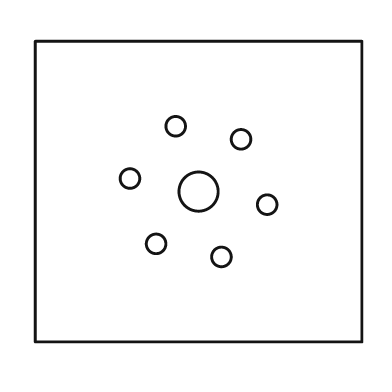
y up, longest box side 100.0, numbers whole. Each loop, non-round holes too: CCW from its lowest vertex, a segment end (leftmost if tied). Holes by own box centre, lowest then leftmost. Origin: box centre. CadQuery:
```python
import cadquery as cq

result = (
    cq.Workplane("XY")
    .moveTo(-50.0, -46.0)
    .lineTo(50.0, -46.0)
    .lineTo(50.0, 46.0)
    .lineTo(-50.0, 46.0)
    .close()
    .moveTo(7.0, -20.0)
    .circle(3.0)
    .moveTo(-13.0, -16.0)
    .circle(3.0)
    .moveTo(21.0, -4.0)
    .circle(3.0)
    .moveTo(0.0, 0.0)
    .circle(6.0)
    .moveTo(-21.0, 4.0)
    .circle(3.0)
    .moveTo(13.0, 16.0)
    .circle(3.0)
    .moveTo(-7.0, 20.0)
    .circle(3.0)
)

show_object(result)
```